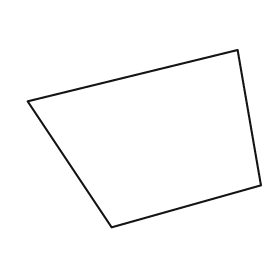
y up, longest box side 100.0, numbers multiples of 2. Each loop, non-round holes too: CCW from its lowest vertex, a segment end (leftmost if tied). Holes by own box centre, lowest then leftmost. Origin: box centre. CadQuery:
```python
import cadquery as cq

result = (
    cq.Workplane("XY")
    .moveTo(-14.0, -38.0)
    .lineTo(50.0, -20.0)
    .lineTo(40.0, 38.0)
    .lineTo(-50.0, 16.0)
    .close()
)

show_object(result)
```